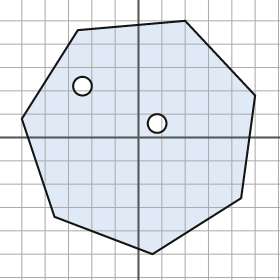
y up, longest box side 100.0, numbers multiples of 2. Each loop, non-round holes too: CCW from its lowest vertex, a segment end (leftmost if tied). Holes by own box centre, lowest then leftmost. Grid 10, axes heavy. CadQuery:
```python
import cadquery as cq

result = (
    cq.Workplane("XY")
    .moveTo(6.0, -50.0)
    .lineTo(44.0, -26.0)
    .lineTo(50.0, 18.0)
    .lineTo(20.0, 50.0)
    .lineTo(-26.0, 46.0)
    .lineTo(-50.0, 8.0)
    .lineTo(-36.0, -34.0)
    .close()
    .moveTo(8.0, 6.0)
    .circle(4.0)
    .moveTo(-24.0, 22.0)
    .circle(4.0)
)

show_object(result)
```